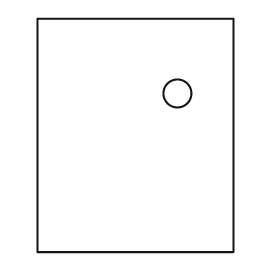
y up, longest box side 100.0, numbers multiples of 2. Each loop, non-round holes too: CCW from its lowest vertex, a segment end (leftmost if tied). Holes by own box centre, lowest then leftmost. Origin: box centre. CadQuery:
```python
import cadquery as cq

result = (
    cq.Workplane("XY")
    .moveTo(-42.0, -50.0)
    .lineTo(42.0, -50.0)
    .lineTo(42.0, 50.0)
    .lineTo(-42.0, 50.0)
    .close()
    .moveTo(18.0, 18.0)
    .circle(6.0)
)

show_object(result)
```